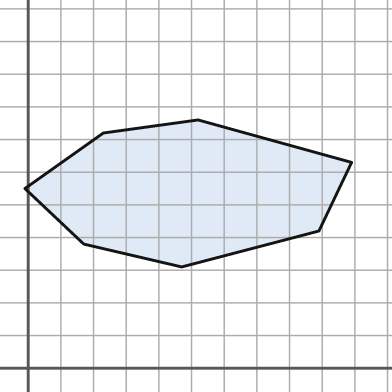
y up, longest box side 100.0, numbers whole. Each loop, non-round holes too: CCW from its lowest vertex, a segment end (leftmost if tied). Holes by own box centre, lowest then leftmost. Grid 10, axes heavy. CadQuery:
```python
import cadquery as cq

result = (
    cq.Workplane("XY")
    .moveTo(47.0, 31.0)
    .lineTo(89.0, 42.0)
    .lineTo(99.0, 63.0)
    .lineTo(52.0, 76.0)
    .lineTo(23.0, 72.0)
    .lineTo(-1.0, 55.0)
    .lineTo(17.0, 38.0)
    .close()
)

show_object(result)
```